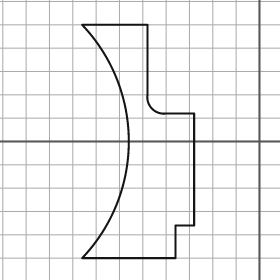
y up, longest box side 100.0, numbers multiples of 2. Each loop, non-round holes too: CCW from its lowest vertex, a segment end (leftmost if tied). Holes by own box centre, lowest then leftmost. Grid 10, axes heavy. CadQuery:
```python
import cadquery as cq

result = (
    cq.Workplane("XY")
    .moveTo(-76.0, -50.0)
    .lineTo(-36.0, -50.0)
    .lineTo(-36.0, -36.0)
    .lineTo(-28.0, -36.0)
    .lineTo(-28.0, 12.0)
    .lineTo(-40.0, 12.0)
    .threePointArc((-46.0, 14.0), (-48.0, 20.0))
    .lineTo(-48.0, 50.0)
    .lineTo(-76.0, 50.0)
    .threePointArc((-56.0, 0.0), (-76.0, -50.0))
    .close()
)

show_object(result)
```